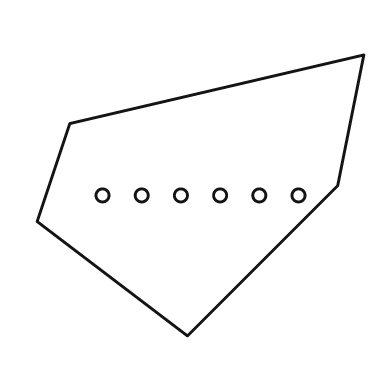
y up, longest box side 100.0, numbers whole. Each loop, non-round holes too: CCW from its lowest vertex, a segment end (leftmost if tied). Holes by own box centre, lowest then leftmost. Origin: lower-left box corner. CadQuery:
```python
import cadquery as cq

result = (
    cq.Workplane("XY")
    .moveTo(46.0, 0.0)
    .lineTo(92.0, 46.0)
    .lineTo(100.0, 86.0)
    .lineTo(10.0, 65.0)
    .lineTo(0.0, 35.0)
    .close()
    .moveTo(20.0, 43.0)
    .circle(2.0)
    .moveTo(32.0, 43.0)
    .circle(2.0)
    .moveTo(44.0, 43.0)
    .circle(2.0)
    .moveTo(56.0, 43.0)
    .circle(2.0)
    .moveTo(68.0, 43.0)
    .circle(2.0)
    .moveTo(80.0, 43.0)
    .circle(2.0)
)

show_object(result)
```